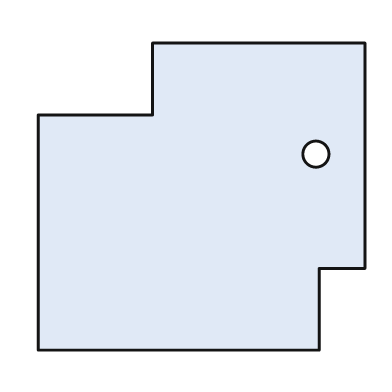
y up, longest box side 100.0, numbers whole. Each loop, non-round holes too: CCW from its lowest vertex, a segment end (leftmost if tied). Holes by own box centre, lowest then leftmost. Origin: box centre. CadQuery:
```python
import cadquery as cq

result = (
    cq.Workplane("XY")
    .moveTo(-50.0, -47.0)
    .lineTo(36.0, -47.0)
    .lineTo(36.0, -22.0)
    .lineTo(50.0, -22.0)
    .lineTo(50.0, 47.0)
    .lineTo(-15.0, 47.0)
    .lineTo(-15.0, 25.0)
    .lineTo(-50.0, 25.0)
    .close()
    .moveTo(35.0, 13.0)
    .circle(4.0)
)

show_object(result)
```